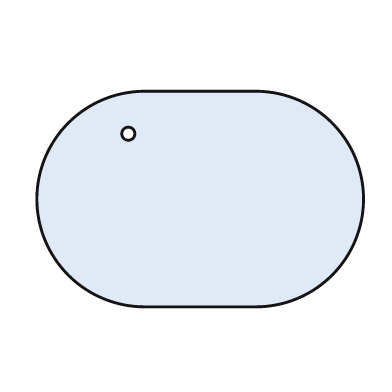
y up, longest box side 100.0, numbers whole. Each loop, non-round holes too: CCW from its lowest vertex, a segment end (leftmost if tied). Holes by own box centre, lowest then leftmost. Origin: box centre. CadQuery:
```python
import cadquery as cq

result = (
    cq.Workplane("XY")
    .moveTo(-17.0, -33.0)
    .lineTo(17.0, -33.0)
    .threePointArc((50.0, 0.0), (17.0, 33.0))
    .lineTo(-17.0, 33.0)
    .threePointArc((-50.0, 0.0), (-17.0, -33.0))
    .close()
    .moveTo(-22.0, 20.0)
    .circle(2.0)
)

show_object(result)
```